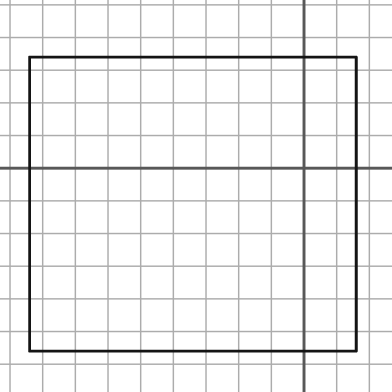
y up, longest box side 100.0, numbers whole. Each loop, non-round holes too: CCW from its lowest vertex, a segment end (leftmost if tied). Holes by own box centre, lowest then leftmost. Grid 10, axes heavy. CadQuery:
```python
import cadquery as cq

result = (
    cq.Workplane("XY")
    .moveTo(-84.0, -56.0)
    .lineTo(16.0, -56.0)
    .lineTo(16.0, 34.0)
    .lineTo(-84.0, 34.0)
    .close()
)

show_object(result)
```